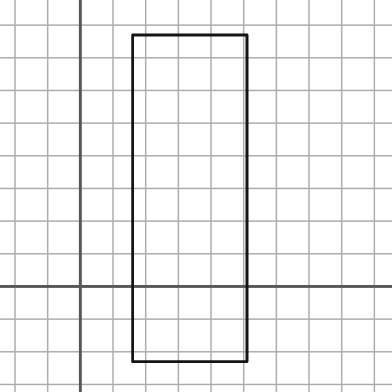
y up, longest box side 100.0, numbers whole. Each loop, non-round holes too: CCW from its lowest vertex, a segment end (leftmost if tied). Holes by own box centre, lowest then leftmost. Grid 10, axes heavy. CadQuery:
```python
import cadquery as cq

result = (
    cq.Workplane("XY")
    .moveTo(16.0, -23.0)
    .lineTo(51.0, -23.0)
    .lineTo(51.0, 77.0)
    .lineTo(16.0, 77.0)
    .close()
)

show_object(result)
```